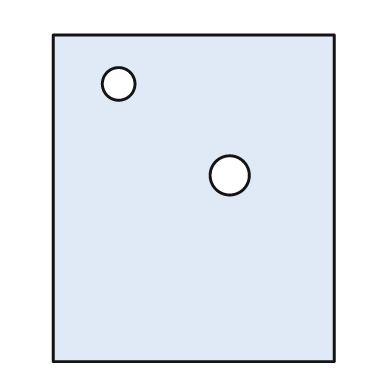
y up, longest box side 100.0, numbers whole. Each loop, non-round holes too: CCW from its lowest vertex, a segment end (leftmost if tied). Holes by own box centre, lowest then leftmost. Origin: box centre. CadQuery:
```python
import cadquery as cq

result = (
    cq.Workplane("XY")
    .moveTo(-43.0, -50.0)
    .lineTo(43.0, -50.0)
    .lineTo(43.0, 50.0)
    .lineTo(-43.0, 50.0)
    .close()
    .moveTo(11.0, 7.0)
    .circle(6.0)
    .moveTo(-23.0, 35.0)
    .circle(5.0)
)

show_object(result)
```